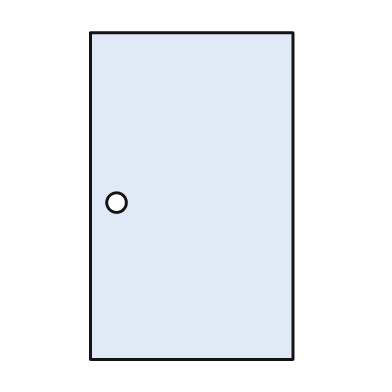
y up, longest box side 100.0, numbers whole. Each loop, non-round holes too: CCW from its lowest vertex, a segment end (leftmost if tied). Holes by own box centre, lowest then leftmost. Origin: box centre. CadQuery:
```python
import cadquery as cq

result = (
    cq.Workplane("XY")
    .moveTo(-31.0, -50.0)
    .lineTo(31.0, -50.0)
    .lineTo(31.0, 50.0)
    .lineTo(-31.0, 50.0)
    .close()
    .moveTo(-23.0, -2.0)
    .circle(3.0)
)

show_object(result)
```